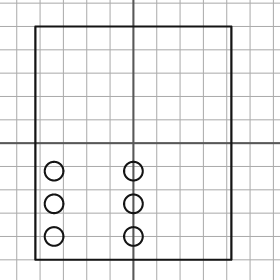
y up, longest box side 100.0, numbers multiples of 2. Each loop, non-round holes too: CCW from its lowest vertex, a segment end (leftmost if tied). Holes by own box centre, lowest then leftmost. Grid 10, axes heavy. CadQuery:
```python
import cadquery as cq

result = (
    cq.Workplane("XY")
    .moveTo(-42.0, -50.0)
    .lineTo(42.0, -50.0)
    .lineTo(42.0, 50.0)
    .lineTo(-42.0, 50.0)
    .close()
    .moveTo(-34.0, -40.0)
    .circle(4.0)
    .moveTo(0.0, -40.0)
    .circle(4.0)
    .moveTo(-34.0, -26.0)
    .circle(4.0)
    .moveTo(0.0, -26.0)
    .circle(4.0)
    .moveTo(-34.0, -12.0)
    .circle(4.0)
    .moveTo(0.0, -12.0)
    .circle(4.0)
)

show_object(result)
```